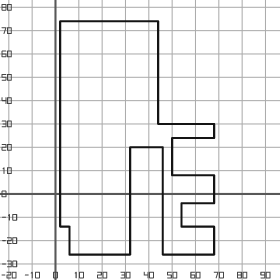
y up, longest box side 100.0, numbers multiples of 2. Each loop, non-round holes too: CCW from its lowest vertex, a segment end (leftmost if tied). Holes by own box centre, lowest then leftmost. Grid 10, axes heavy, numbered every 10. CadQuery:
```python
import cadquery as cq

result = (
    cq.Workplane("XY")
    .moveTo(6.0, -26.0)
    .lineTo(32.0, -26.0)
    .lineTo(32.0, 20.0)
    .lineTo(46.0, 20.0)
    .lineTo(46.0, -26.0)
    .lineTo(68.0, -26.0)
    .lineTo(68.0, -14.0)
    .lineTo(54.0, -14.0)
    .lineTo(54.0, -4.0)
    .lineTo(68.0, -4.0)
    .lineTo(68.0, 8.0)
    .lineTo(50.0, 8.0)
    .lineTo(50.0, 24.0)
    .lineTo(68.0, 24.0)
    .lineTo(68.0, 30.0)
    .lineTo(44.0, 30.0)
    .lineTo(44.0, 74.0)
    .lineTo(2.0, 74.0)
    .lineTo(2.0, -14.0)
    .lineTo(6.0, -14.0)
    .close()
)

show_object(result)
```